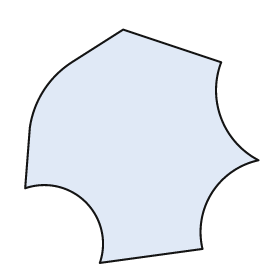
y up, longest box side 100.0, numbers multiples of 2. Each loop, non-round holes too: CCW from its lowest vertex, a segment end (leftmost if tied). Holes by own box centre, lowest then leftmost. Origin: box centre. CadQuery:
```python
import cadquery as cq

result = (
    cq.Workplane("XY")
    .moveTo(-18.0, -50.0)
    .lineTo(26.0, -44.0)
    .threePointArc((30.0, -20.0), (50.0, -6.0))
    .threePointArc((34.0, 12.0), (34.0, 36.0))
    .lineTo(-8.0, 50.0)
    .lineTo(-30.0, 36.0)
    .threePointArc((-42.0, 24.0), (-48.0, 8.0))
    .lineTo(-50.0, -18.0)
    .threePointArc((-24.0, -24.0), (-18.0, -50.0))
    .close()
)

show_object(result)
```